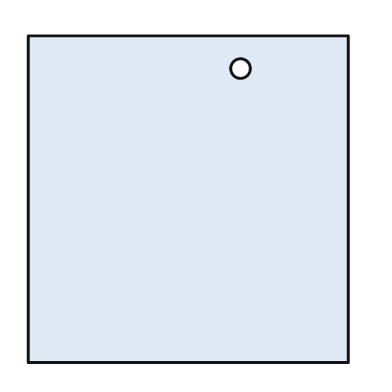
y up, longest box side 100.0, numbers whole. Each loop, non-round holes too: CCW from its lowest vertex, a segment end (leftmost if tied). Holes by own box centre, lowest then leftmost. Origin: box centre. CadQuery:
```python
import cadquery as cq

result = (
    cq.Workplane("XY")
    .moveTo(-49.0, -50.0)
    .lineTo(49.0, -50.0)
    .lineTo(49.0, 50.0)
    .lineTo(-49.0, 50.0)
    .close()
    .moveTo(16.0, 40.0)
    .circle(3.0)
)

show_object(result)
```